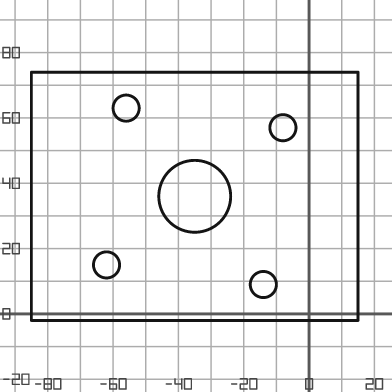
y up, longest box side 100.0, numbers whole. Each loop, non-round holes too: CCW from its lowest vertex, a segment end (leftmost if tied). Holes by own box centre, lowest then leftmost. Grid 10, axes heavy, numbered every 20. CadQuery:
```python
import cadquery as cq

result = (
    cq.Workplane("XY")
    .moveTo(-85.0, -2.0)
    .lineTo(15.0, -2.0)
    .lineTo(15.0, 74.0)
    .lineTo(-85.0, 74.0)
    .close()
    .moveTo(-14.0, 9.0)
    .circle(4.0)
    .moveTo(-62.0, 15.0)
    .circle(4.0)
    .moveTo(-35.0, 36.0)
    .circle(11.0)
    .moveTo(-8.0, 57.0)
    .circle(4.0)
    .moveTo(-56.0, 63.0)
    .circle(4.0)
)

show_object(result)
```